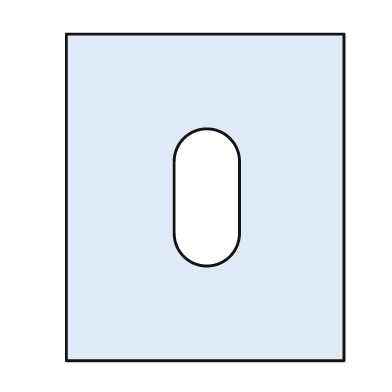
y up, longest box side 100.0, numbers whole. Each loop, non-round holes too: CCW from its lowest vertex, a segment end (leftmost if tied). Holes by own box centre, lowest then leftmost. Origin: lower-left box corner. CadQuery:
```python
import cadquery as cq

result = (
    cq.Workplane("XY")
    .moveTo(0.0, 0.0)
    .lineTo(85.0, 0.0)
    .lineTo(85.0, 100.0)
    .lineTo(0.0, 100.0)
    .close()
    .moveTo(33.0, 39.0)
    .threePointArc((43.0, 29.0), (53.0, 39.0))
    .lineTo(53.0, 61.0)
    .threePointArc((43.0, 71.0), (33.0, 61.0))
    .close()
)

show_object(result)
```